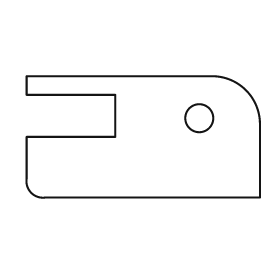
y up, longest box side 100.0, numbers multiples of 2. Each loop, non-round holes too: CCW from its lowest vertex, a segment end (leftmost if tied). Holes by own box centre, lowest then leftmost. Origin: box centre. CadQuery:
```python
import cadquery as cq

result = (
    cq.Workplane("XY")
    .moveTo(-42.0, -26.0)
    .lineTo(50.0, -26.0)
    .lineTo(50.0, 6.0)
    .threePointArc((44.0, 20.0), (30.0, 26.0))
    .lineTo(-50.0, 26.0)
    .lineTo(-50.0, 18.0)
    .lineTo(-12.0, 18.0)
    .lineTo(-12.0, 0.0)
    .lineTo(-50.0, 0.0)
    .lineTo(-50.0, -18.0)
    .threePointArc((-48.0, -24.0), (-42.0, -26.0))
    .close()
    .moveTo(24.0, 8.0)
    .circle(6.0)
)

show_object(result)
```